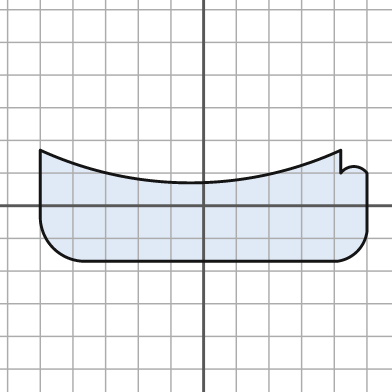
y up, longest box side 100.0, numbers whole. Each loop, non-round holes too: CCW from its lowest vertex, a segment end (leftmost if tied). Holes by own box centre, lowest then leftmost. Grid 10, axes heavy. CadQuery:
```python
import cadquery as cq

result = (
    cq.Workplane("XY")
    .moveTo(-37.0, -17.0)
    .lineTo(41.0, -17.0)
    .threePointArc((47.0, -14.0), (50.0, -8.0))
    .lineTo(50.0, 10.0)
    .threePointArc((46.0, 12.0), (42.0, 10.0))
    .lineTo(42.0, 17.0)
    .threePointArc((-4.0, 7.0), (-50.0, 17.0))
    .lineTo(-50.0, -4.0)
    .threePointArc((-46.0, -13.0), (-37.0, -17.0))
    .close()
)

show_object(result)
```